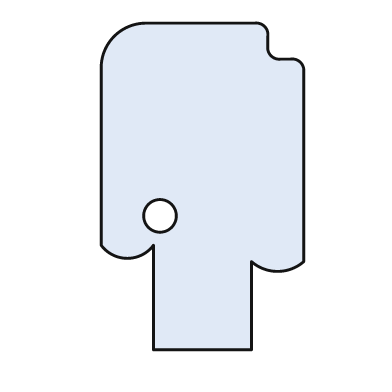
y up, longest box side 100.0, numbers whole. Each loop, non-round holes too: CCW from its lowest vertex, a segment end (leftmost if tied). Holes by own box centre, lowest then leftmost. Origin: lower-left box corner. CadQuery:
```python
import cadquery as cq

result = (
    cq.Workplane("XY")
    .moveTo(16.0, 0.0)
    .lineTo(46.0, 0.0)
    .lineTo(46.0, 27.0)
    .threePointArc((54.0, 24.0), (62.0, 27.0))
    .lineTo(62.0, 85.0)
    .threePointArc((61.0, 88.0), (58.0, 89.0))
    .lineTo(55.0, 89.0)
    .threePointArc((52.0, 90.0), (51.0, 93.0))
    .lineTo(51.0, 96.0)
    .threePointArc((50.0, 99.0), (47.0, 100.0))
    .lineTo(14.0, 100.0)
    .threePointArc((4.0, 96.0), (0.0, 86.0))
    .lineTo(0.0, 32.0)
    .threePointArc((8.0, 28.0), (16.0, 32.0))
    .close()
    .moveTo(18.0, 41.0)
    .circle(5.0)
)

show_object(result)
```